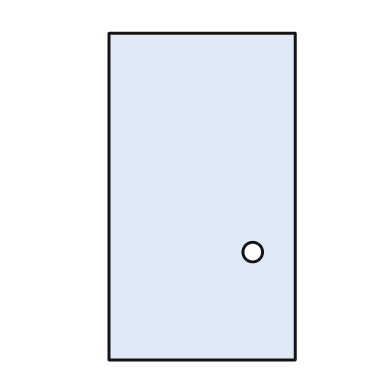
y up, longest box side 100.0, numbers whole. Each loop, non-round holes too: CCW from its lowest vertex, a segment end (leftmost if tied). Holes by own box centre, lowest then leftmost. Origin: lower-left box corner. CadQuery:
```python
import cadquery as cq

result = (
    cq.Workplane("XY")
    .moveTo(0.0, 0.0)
    .lineTo(57.0, 0.0)
    .lineTo(57.0, 100.0)
    .lineTo(0.0, 100.0)
    .close()
    .moveTo(44.0, 33.0)
    .circle(3.0)
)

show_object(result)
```